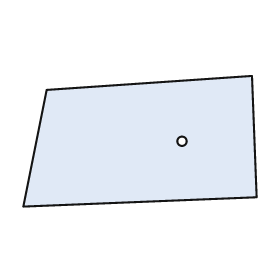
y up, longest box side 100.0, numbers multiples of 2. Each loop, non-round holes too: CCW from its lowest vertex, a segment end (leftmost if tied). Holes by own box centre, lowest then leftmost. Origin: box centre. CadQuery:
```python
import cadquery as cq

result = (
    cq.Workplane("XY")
    .moveTo(-50.0, -28.0)
    .lineTo(50.0, -24.0)
    .lineTo(48.0, 28.0)
    .lineTo(-40.0, 22.0)
    .close()
    .moveTo(18.0, 0.0)
    .circle(2.0)
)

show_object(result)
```